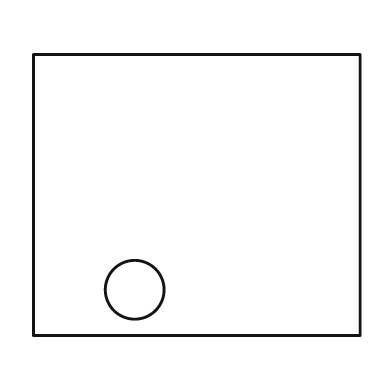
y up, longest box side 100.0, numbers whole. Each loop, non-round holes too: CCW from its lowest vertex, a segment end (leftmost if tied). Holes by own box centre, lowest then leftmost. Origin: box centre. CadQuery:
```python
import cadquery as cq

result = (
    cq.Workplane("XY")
    .moveTo(-50.0, -43.0)
    .lineTo(50.0, -43.0)
    .lineTo(50.0, 43.0)
    .lineTo(-50.0, 43.0)
    .close()
    .moveTo(-19.0, -29.0)
    .circle(9.0)
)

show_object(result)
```